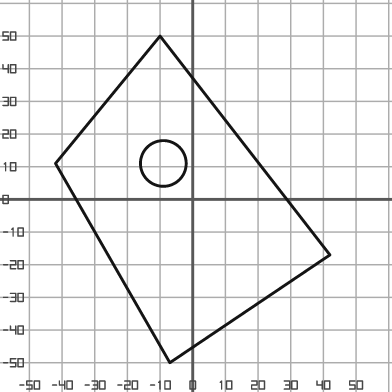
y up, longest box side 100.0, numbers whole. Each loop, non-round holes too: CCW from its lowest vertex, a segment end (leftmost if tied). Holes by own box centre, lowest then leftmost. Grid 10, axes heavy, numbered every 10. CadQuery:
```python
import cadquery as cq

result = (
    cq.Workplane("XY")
    .moveTo(-7.0, -50.0)
    .lineTo(42.0, -17.0)
    .lineTo(-10.0, 50.0)
    .lineTo(-42.0, 11.0)
    .close()
    .moveTo(-9.0, 11.0)
    .circle(7.0)
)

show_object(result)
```